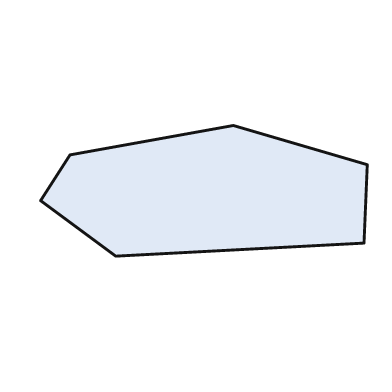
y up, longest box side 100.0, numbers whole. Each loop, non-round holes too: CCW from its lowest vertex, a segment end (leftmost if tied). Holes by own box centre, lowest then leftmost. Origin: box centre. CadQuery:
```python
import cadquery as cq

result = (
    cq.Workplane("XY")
    .moveTo(-27.0, -20.0)
    .lineTo(49.0, -16.0)
    .lineTo(50.0, 8.0)
    .lineTo(9.0, 20.0)
    .lineTo(-41.0, 11.0)
    .lineTo(-50.0, -3.0)
    .close()
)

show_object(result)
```